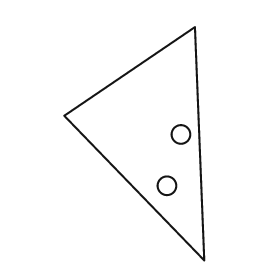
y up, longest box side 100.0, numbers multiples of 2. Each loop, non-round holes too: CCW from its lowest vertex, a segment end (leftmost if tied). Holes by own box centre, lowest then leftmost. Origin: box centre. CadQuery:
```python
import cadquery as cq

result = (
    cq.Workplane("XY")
    .moveTo(30.0, -50.0)
    .lineTo(26.0, 50.0)
    .lineTo(-30.0, 12.0)
    .close()
    .moveTo(14.0, -18.0)
    .circle(4.0)
    .moveTo(20.0, 4.0)
    .circle(4.0)
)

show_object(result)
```